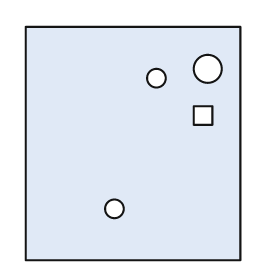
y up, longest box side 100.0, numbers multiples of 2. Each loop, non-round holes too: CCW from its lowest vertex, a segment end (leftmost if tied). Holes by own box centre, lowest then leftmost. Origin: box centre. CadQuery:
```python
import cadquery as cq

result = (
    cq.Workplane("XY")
    .moveTo(-46.0, -50.0)
    .lineTo(46.0, -50.0)
    .lineTo(46.0, 50.0)
    .lineTo(-46.0, 50.0)
    .close()
    .moveTo(-8.0, -28.0)
    .circle(4.0)
    .moveTo(26.0, 8.0)
    .lineTo(34.0, 8.0)
    .lineTo(34.0, 16.0)
    .lineTo(26.0, 16.0)
    .close()
    .moveTo(10.0, 28.0)
    .circle(4.0)
    .moveTo(32.0, 32.0)
    .circle(6.0)
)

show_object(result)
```